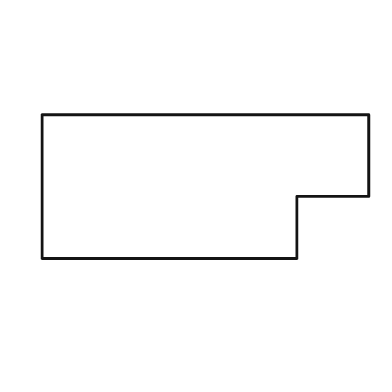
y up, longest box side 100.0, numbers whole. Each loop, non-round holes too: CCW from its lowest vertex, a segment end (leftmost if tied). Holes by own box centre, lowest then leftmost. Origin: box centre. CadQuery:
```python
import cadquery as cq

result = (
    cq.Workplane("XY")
    .moveTo(-50.0, -22.0)
    .lineTo(28.0, -22.0)
    .lineTo(28.0, -3.0)
    .lineTo(50.0, -3.0)
    .lineTo(50.0, 22.0)
    .lineTo(-50.0, 22.0)
    .close()
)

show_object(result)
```